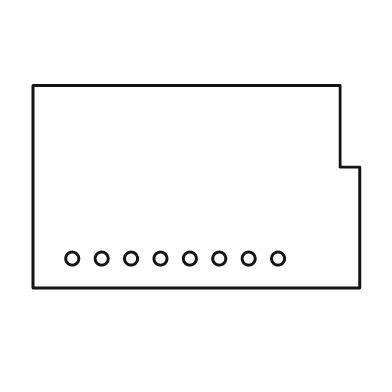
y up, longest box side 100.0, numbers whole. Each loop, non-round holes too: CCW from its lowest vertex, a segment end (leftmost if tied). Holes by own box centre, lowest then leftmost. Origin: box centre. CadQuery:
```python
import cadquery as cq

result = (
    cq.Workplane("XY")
    .moveTo(-50.0, -31.0)
    .lineTo(50.0, -31.0)
    .lineTo(50.0, 6.0)
    .lineTo(44.0, 6.0)
    .lineTo(44.0, 31.0)
    .lineTo(-50.0, 31.0)
    .close()
    .moveTo(-38.0, -22.0)
    .circle(2.0)
    .moveTo(-29.0, -22.0)
    .circle(2.0)
    .moveTo(-20.0, -22.0)
    .circle(2.0)
    .moveTo(-11.0, -22.0)
    .circle(2.0)
    .moveTo(-2.0, -22.0)
    .circle(2.0)
    .moveTo(7.0, -22.0)
    .circle(2.0)
    .moveTo(16.0, -22.0)
    .circle(2.0)
    .moveTo(25.0, -22.0)
    .circle(2.0)
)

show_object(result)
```